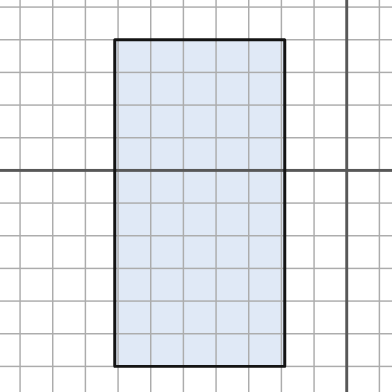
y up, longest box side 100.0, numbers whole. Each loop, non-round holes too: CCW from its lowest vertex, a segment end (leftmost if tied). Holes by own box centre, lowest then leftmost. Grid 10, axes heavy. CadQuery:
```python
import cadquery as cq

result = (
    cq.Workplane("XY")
    .moveTo(-71.0, -60.0)
    .lineTo(-19.0, -60.0)
    .lineTo(-19.0, 40.0)
    .lineTo(-71.0, 40.0)
    .close()
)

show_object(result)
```